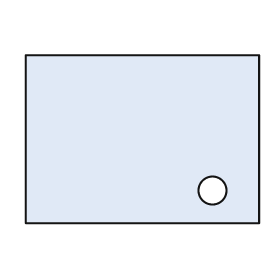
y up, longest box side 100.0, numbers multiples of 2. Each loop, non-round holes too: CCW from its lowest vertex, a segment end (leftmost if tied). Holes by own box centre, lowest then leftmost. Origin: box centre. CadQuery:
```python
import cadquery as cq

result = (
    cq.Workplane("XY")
    .moveTo(-50.0, -36.0)
    .lineTo(50.0, -36.0)
    .lineTo(50.0, 36.0)
    .lineTo(-50.0, 36.0)
    .close()
    .moveTo(30.0, -22.0)
    .circle(6.0)
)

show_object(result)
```